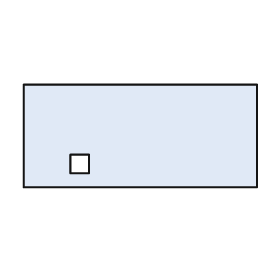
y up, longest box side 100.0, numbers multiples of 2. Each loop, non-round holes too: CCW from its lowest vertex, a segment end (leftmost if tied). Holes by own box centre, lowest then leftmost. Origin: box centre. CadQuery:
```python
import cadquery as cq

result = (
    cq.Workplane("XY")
    .moveTo(-50.0, -22.0)
    .lineTo(50.0, -22.0)
    .lineTo(50.0, 22.0)
    .lineTo(-50.0, 22.0)
    .close()
    .moveTo(-30.0, -16.0)
    .lineTo(-22.0, -16.0)
    .lineTo(-22.0, -8.0)
    .lineTo(-30.0, -8.0)
    .close()
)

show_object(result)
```